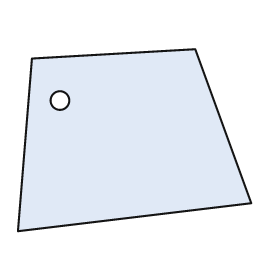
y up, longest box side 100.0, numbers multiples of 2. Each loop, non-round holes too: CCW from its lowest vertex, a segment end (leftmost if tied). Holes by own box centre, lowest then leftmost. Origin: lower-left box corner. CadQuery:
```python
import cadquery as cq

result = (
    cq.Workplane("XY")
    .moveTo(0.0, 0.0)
    .lineTo(100.0, 12.0)
    .lineTo(76.0, 78.0)
    .lineTo(6.0, 74.0)
    .close()
    .moveTo(18.0, 56.0)
    .circle(4.0)
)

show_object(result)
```